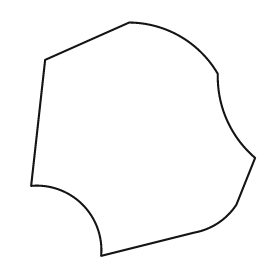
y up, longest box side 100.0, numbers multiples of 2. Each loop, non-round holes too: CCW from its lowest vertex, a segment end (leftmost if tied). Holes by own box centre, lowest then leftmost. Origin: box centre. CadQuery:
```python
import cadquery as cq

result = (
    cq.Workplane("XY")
    .moveTo(-18.0, -50.0)
    .lineTo(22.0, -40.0)
    .threePointArc((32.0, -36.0), (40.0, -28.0))
    .lineTo(48.0, -8.0)
    .threePointArc((36.0, 8.0), (32.0, 28.0))
    .threePointArc((16.0, 44.0), (-6.0, 50.0))
    .lineTo(-42.0, 34.0)
    .lineTo(-48.0, -20.0)
    .threePointArc((-26.0, -28.0), (-18.0, -50.0))
    .close()
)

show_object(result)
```